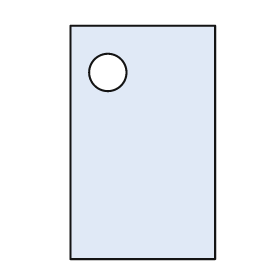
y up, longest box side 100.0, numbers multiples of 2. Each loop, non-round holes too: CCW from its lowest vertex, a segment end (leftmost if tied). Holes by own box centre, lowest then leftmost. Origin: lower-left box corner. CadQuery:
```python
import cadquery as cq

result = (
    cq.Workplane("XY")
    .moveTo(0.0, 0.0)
    .lineTo(62.0, 0.0)
    .lineTo(62.0, 100.0)
    .lineTo(0.0, 100.0)
    .close()
    .moveTo(16.0, 80.0)
    .circle(8.0)
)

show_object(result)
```